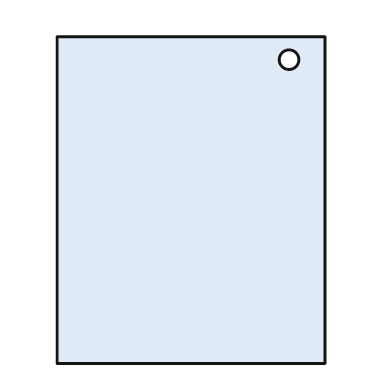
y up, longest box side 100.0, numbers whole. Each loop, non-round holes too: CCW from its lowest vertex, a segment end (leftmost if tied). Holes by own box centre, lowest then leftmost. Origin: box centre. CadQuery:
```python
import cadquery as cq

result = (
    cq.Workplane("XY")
    .moveTo(-41.0, -50.0)
    .lineTo(41.0, -50.0)
    .lineTo(41.0, 50.0)
    .lineTo(-41.0, 50.0)
    .close()
    .moveTo(30.0, 43.0)
    .circle(3.0)
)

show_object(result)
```